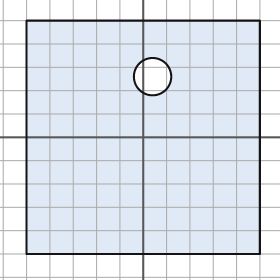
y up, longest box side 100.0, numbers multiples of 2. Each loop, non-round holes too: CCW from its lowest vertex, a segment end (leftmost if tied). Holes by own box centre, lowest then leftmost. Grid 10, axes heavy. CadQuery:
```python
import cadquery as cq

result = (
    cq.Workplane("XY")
    .moveTo(-50.0, -50.0)
    .lineTo(50.0, -50.0)
    .lineTo(50.0, 50.0)
    .lineTo(-50.0, 50.0)
    .close()
    .moveTo(4.0, 26.0)
    .circle(8.0)
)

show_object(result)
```